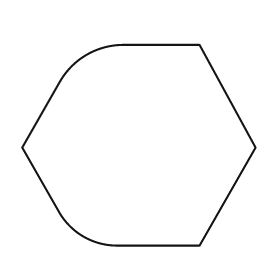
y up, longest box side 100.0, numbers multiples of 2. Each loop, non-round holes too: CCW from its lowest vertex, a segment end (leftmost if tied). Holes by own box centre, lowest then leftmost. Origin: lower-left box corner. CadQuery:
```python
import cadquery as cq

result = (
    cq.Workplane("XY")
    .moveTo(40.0, 0.0)
    .lineTo(76.0, 0.0)
    .lineTo(100.0, 42.0)
    .lineTo(76.0, 86.0)
    .lineTo(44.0, 86.0)
    .threePointArc((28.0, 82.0), (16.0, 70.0))
    .lineTo(0.0, 42.0)
    .lineTo(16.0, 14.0)
    .threePointArc((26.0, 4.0), (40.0, 0.0))
    .close()
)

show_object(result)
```